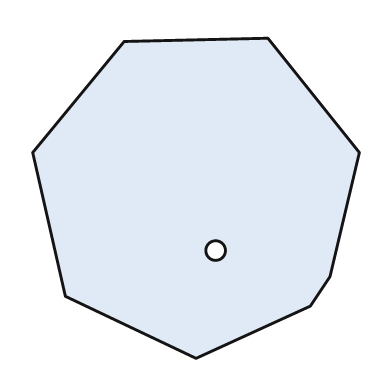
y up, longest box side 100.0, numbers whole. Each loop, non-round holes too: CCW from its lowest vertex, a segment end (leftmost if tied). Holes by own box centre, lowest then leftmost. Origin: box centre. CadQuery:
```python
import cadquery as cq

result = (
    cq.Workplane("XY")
    .moveTo(0.0, -49.0)
    .lineTo(35.0, -33.0)
    .lineTo(41.0, -24.0)
    .lineTo(50.0, 14.0)
    .lineTo(22.0, 49.0)
    .lineTo(-22.0, 48.0)
    .lineTo(-50.0, 14.0)
    .lineTo(-40.0, -30.0)
    .close()
    .moveTo(6.0, -16.0)
    .circle(3.0)
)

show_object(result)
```